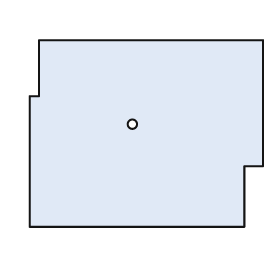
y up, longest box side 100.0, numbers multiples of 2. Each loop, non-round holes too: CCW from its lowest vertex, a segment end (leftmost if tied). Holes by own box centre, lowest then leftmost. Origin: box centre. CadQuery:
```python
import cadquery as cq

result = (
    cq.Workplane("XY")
    .moveTo(-50.0, -40.0)
    .lineTo(42.0, -40.0)
    .lineTo(42.0, -14.0)
    .lineTo(50.0, -14.0)
    .lineTo(50.0, 40.0)
    .lineTo(-46.0, 40.0)
    .lineTo(-46.0, 16.0)
    .lineTo(-50.0, 16.0)
    .close()
    .moveTo(-6.0, 4.0)
    .circle(2.0)
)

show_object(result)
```